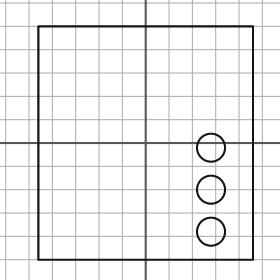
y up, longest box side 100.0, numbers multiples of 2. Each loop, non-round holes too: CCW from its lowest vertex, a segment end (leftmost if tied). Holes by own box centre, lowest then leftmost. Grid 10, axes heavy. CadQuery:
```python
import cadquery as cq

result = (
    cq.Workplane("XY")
    .moveTo(-46.0, -50.0)
    .lineTo(46.0, -50.0)
    .lineTo(46.0, 50.0)
    .lineTo(-46.0, 50.0)
    .close()
    .moveTo(28.0, -38.0)
    .circle(6.0)
    .moveTo(28.0, -20.0)
    .circle(6.0)
    .moveTo(28.0, -2.0)
    .circle(6.0)
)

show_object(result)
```